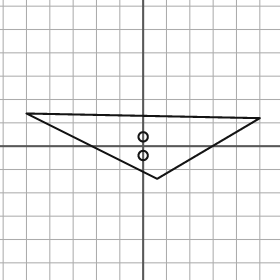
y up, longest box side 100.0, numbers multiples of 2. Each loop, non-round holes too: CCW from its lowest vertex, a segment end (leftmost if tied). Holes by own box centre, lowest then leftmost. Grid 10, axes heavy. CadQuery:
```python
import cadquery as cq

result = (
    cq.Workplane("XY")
    .moveTo(6.0, -14.0)
    .lineTo(50.0, 12.0)
    .lineTo(-50.0, 14.0)
    .close()
    .moveTo(0.0, -4.0)
    .circle(2.0)
    .moveTo(0.0, 4.0)
    .circle(2.0)
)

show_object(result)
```